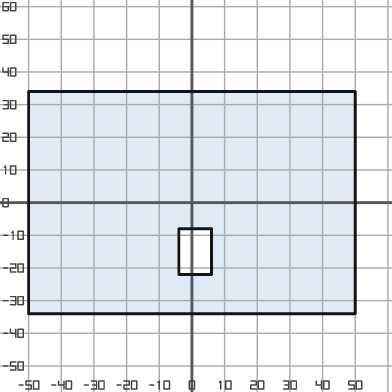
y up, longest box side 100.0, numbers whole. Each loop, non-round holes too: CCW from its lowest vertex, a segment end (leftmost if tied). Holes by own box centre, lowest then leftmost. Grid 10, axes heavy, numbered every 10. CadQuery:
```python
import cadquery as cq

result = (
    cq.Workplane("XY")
    .moveTo(-50.0, -34.0)
    .lineTo(50.0, -34.0)
    .lineTo(50.0, 34.0)
    .lineTo(-50.0, 34.0)
    .close()
    .moveTo(-4.0, -22.0)
    .lineTo(6.0, -22.0)
    .lineTo(6.0, -8.0)
    .lineTo(-4.0, -8.0)
    .close()
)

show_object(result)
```